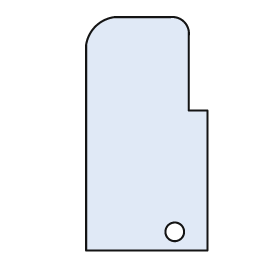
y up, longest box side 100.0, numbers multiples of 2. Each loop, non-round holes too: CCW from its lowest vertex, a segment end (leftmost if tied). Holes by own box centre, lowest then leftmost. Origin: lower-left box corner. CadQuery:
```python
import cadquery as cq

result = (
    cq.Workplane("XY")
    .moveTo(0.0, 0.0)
    .lineTo(52.0, 0.0)
    .lineTo(52.0, 60.0)
    .lineTo(44.0, 60.0)
    .lineTo(44.0, 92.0)
    .threePointArc((42.0, 98.0), (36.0, 100.0))
    .lineTo(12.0, 100.0)
    .threePointArc((4.0, 96.0), (0.0, 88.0))
    .close()
    .moveTo(38.0, 8.0)
    .circle(4.0)
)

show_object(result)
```